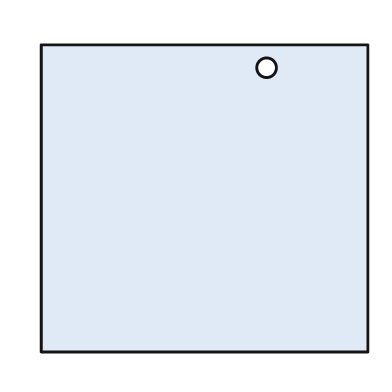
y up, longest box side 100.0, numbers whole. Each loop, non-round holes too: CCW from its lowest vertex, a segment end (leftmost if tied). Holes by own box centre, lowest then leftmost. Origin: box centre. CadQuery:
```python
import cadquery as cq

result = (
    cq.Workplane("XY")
    .moveTo(-50.0, -47.0)
    .lineTo(50.0, -47.0)
    .lineTo(50.0, 47.0)
    .lineTo(-50.0, 47.0)
    .close()
    .moveTo(19.0, 40.0)
    .circle(3.0)
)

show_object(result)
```